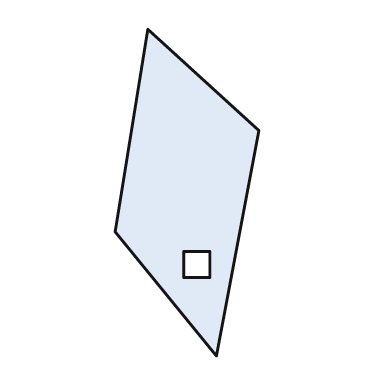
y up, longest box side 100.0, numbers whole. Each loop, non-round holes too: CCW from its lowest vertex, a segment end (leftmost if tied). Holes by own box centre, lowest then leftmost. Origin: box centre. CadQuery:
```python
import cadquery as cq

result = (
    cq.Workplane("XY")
    .moveTo(9.0, -50.0)
    .lineTo(22.0, 19.0)
    .lineTo(-12.0, 50.0)
    .lineTo(-22.0, -12.0)
    .close()
    .moveTo(-1.0, -26.0)
    .lineTo(7.0, -26.0)
    .lineTo(7.0, -18.0)
    .lineTo(-1.0, -18.0)
    .close()
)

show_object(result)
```